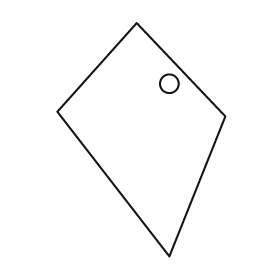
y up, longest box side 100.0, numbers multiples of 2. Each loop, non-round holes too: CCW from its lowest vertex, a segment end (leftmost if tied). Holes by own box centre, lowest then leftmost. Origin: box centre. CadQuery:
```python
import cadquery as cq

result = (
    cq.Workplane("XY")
    .moveTo(12.0, -50.0)
    .lineTo(36.0, 10.0)
    .lineTo(-2.0, 50.0)
    .lineTo(-36.0, 12.0)
    .close()
    .moveTo(12.0, 24.0)
    .circle(4.0)
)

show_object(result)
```